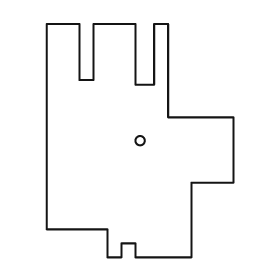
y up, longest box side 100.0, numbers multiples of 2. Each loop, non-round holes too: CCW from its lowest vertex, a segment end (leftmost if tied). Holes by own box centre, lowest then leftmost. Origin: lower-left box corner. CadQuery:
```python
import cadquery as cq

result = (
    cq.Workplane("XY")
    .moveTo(26.0, 0.0)
    .lineTo(32.0, 0.0)
    .lineTo(32.0, 6.0)
    .lineTo(38.0, 6.0)
    .lineTo(38.0, 0.0)
    .lineTo(62.0, 0.0)
    .lineTo(62.0, 32.0)
    .lineTo(80.0, 32.0)
    .lineTo(80.0, 60.0)
    .lineTo(52.0, 60.0)
    .lineTo(52.0, 100.0)
    .lineTo(46.0, 100.0)
    .lineTo(46.0, 74.0)
    .lineTo(38.0, 74.0)
    .lineTo(38.0, 100.0)
    .lineTo(20.0, 100.0)
    .lineTo(20.0, 76.0)
    .lineTo(14.0, 76.0)
    .lineTo(14.0, 100.0)
    .lineTo(0.0, 100.0)
    .lineTo(0.0, 12.0)
    .lineTo(26.0, 12.0)
    .close()
    .moveTo(40.0, 50.0)
    .circle(2.0)
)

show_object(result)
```